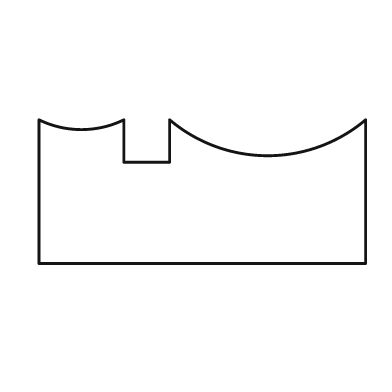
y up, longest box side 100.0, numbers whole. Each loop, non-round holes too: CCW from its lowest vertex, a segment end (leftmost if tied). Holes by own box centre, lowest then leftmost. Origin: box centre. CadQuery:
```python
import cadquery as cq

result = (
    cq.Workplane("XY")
    .moveTo(-50.0, -22.0)
    .lineTo(50.0, -22.0)
    .lineTo(50.0, 22.0)
    .threePointArc((20.0, 11.0), (-10.0, 22.0))
    .lineTo(-10.0, 9.0)
    .lineTo(-24.0, 9.0)
    .lineTo(-24.0, 22.0)
    .threePointArc((-37.0, 19.0), (-50.0, 22.0))
    .close()
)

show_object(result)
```